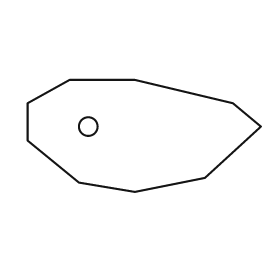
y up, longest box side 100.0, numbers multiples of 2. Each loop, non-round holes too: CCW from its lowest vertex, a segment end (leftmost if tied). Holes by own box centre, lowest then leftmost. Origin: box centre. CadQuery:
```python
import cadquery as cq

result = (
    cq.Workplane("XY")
    .moveTo(-4.0, -24.0)
    .lineTo(26.0, -18.0)
    .lineTo(50.0, 4.0)
    .lineTo(38.0, 14.0)
    .lineTo(-4.0, 24.0)
    .lineTo(-32.0, 24.0)
    .lineTo(-50.0, 14.0)
    .lineTo(-50.0, -2.0)
    .lineTo(-28.0, -20.0)
    .close()
    .moveTo(-24.0, 4.0)
    .circle(4.0)
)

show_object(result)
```